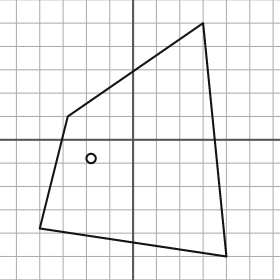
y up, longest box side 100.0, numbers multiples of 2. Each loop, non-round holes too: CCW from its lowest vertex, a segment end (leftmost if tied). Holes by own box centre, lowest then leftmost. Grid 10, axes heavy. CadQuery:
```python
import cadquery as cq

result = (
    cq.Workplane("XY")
    .moveTo(40.0, -50.0)
    .lineTo(30.0, 50.0)
    .lineTo(-28.0, 10.0)
    .lineTo(-40.0, -38.0)
    .close()
    .moveTo(-18.0, -8.0)
    .circle(2.0)
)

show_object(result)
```